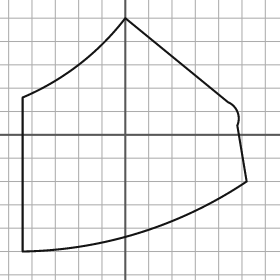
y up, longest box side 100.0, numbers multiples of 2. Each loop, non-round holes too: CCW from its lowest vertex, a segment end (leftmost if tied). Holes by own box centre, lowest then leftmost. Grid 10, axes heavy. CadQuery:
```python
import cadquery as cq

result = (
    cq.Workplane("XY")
    .moveTo(-44.0, -50.0)
    .threePointArc((6.0, -42.0), (52.0, -20.0))
    .lineTo(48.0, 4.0)
    .threePointArc((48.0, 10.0), (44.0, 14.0))
    .lineTo(0.0, 50.0)
    .threePointArc((-20.0, 30.0), (-44.0, 16.0))
    .close()
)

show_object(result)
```